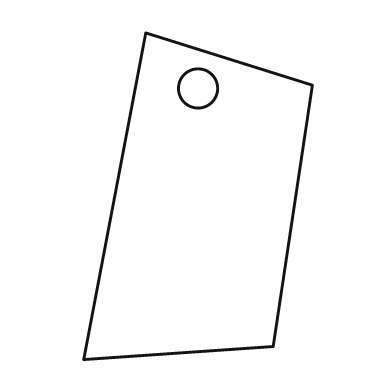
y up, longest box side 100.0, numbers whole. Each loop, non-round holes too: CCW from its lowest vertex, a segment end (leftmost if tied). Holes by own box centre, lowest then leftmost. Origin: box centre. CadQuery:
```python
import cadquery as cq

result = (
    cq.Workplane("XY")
    .moveTo(-35.0, -50.0)
    .lineTo(23.0, -46.0)
    .lineTo(35.0, 34.0)
    .lineTo(-16.0, 50.0)
    .close()
    .moveTo(0.0, 33.0)
    .circle(6.0)
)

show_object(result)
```